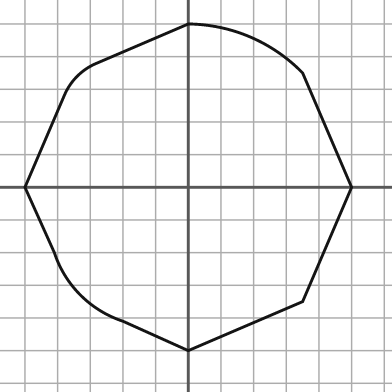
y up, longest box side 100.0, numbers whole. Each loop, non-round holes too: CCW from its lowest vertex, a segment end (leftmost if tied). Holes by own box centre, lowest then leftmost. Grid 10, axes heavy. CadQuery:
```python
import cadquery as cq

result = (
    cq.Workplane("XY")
    .moveTo(0.0, -50.0)
    .lineTo(35.0, -35.0)
    .lineTo(50.0, 0.0)
    .lineTo(35.0, 35.0)
    .threePointArc((19.0, 46.0), (0.0, 50.0))
    .lineTo(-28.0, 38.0)
    .threePointArc((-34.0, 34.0), (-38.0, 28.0))
    .lineTo(-50.0, 0.0)
    .lineTo(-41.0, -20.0)
    .threePointArc((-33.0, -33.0), (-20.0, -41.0))
    .close()
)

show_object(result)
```